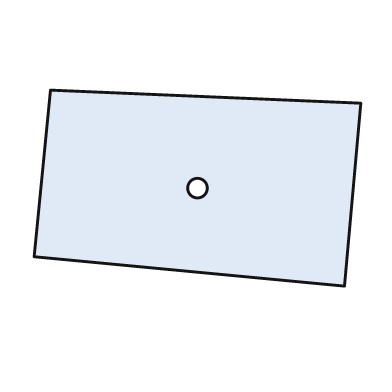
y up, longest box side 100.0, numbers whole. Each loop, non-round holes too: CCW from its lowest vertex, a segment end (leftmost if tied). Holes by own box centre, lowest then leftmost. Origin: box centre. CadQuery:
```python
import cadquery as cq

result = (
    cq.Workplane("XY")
    .moveTo(45.0, -30.0)
    .lineTo(50.0, 26.0)
    .lineTo(-45.0, 30.0)
    .lineTo(-50.0, -21.0)
    .close()
    .moveTo(0.0, 0.0)
    .circle(3.0)
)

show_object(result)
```